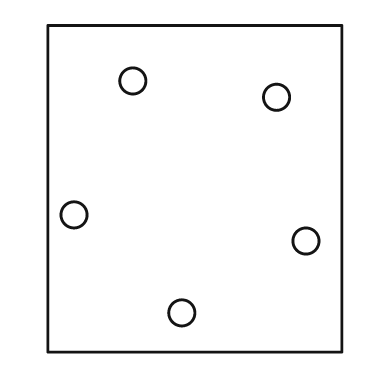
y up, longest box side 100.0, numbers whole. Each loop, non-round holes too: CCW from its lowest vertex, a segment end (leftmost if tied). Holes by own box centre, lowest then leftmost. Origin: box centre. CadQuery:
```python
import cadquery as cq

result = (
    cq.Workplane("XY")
    .moveTo(-45.0, -50.0)
    .lineTo(45.0, -50.0)
    .lineTo(45.0, 50.0)
    .lineTo(-45.0, 50.0)
    .close()
    .moveTo(-4.0, -38.0)
    .circle(4.0)
    .moveTo(34.0, -16.0)
    .circle(4.0)
    .moveTo(-37.0, -8.0)
    .circle(4.0)
    .moveTo(25.0, 28.0)
    .circle(4.0)
    .moveTo(-19.0, 33.0)
    .circle(4.0)
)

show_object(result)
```